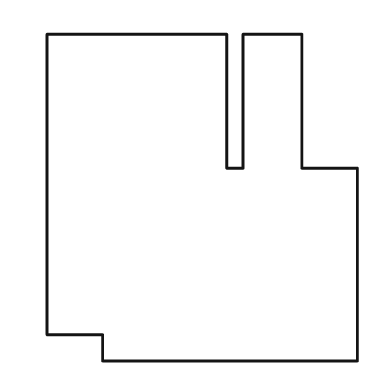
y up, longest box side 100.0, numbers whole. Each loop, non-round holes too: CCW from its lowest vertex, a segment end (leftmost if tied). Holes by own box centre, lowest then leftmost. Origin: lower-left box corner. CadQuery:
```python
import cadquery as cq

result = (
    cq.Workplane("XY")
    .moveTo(17.0, 0.0)
    .lineTo(95.0, 0.0)
    .lineTo(95.0, 59.0)
    .lineTo(78.0, 59.0)
    .lineTo(78.0, 100.0)
    .lineTo(60.0, 100.0)
    .lineTo(60.0, 59.0)
    .lineTo(55.0, 59.0)
    .lineTo(55.0, 100.0)
    .lineTo(0.0, 100.0)
    .lineTo(0.0, 8.0)
    .lineTo(17.0, 8.0)
    .close()
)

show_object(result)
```